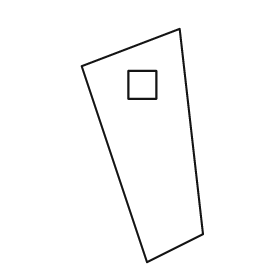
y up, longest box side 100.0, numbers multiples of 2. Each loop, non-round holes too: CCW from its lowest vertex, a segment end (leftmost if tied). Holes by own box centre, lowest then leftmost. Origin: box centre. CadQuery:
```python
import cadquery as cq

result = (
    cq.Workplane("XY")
    .moveTo(2.0, -50.0)
    .lineTo(26.0, -38.0)
    .lineTo(16.0, 50.0)
    .lineTo(-26.0, 34.0)
    .close()
    .moveTo(-6.0, 20.0)
    .lineTo(6.0, 20.0)
    .lineTo(6.0, 32.0)
    .lineTo(-6.0, 32.0)
    .close()
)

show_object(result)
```